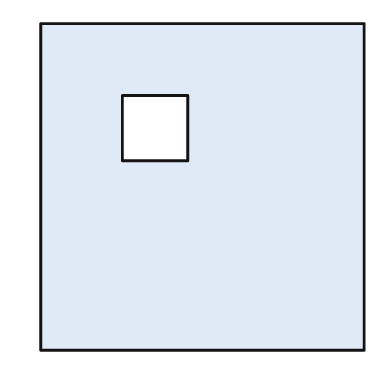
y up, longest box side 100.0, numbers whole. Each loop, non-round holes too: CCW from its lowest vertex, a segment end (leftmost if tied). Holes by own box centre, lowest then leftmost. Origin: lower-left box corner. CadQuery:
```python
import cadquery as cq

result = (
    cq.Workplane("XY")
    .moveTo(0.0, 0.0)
    .lineTo(99.0, 0.0)
    .lineTo(99.0, 100.0)
    .lineTo(0.0, 100.0)
    .close()
    .moveTo(25.0, 58.0)
    .lineTo(45.0, 58.0)
    .lineTo(45.0, 78.0)
    .lineTo(25.0, 78.0)
    .close()
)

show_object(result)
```